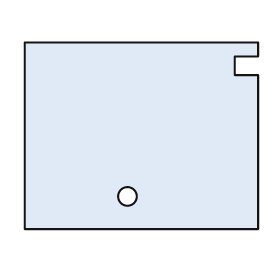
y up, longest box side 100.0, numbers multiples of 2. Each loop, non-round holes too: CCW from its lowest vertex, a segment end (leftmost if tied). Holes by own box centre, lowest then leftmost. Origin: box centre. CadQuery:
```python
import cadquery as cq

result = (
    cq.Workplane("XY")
    .moveTo(-50.0, -40.0)
    .lineTo(50.0, -40.0)
    .lineTo(50.0, 26.0)
    .lineTo(40.0, 26.0)
    .lineTo(40.0, 34.0)
    .lineTo(50.0, 34.0)
    .lineTo(50.0, 40.0)
    .lineTo(-50.0, 40.0)
    .close()
    .moveTo(-6.0, -26.0)
    .circle(4.0)
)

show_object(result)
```